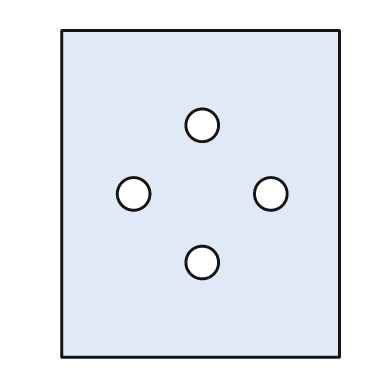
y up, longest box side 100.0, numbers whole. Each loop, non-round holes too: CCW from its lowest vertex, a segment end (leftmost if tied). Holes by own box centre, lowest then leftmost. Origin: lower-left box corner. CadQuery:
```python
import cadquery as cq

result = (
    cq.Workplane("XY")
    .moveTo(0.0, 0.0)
    .lineTo(85.0, 0.0)
    .lineTo(85.0, 100.0)
    .lineTo(0.0, 100.0)
    .close()
    .moveTo(43.0, 29.0)
    .circle(5.0)
    .moveTo(22.0, 50.0)
    .circle(5.0)
    .moveTo(64.0, 50.0)
    .circle(5.0)
    .moveTo(43.0, 71.0)
    .circle(5.0)
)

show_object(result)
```